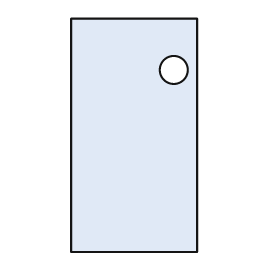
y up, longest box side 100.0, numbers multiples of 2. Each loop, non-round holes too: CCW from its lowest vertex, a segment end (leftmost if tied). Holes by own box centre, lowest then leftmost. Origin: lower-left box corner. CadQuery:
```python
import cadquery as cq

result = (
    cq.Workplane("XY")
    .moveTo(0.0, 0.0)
    .lineTo(54.0, 0.0)
    .lineTo(54.0, 100.0)
    .lineTo(0.0, 100.0)
    .close()
    .moveTo(44.0, 78.0)
    .circle(6.0)
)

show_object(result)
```